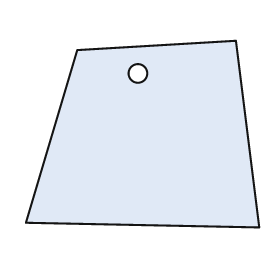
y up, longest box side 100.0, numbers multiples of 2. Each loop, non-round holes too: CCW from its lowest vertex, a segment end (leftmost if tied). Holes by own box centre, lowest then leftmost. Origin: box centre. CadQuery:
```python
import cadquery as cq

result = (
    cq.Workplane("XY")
    .moveTo(50.0, -40.0)
    .lineTo(40.0, 40.0)
    .lineTo(-28.0, 36.0)
    .lineTo(-50.0, -38.0)
    .close()
    .moveTo(-2.0, 26.0)
    .circle(4.0)
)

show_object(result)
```